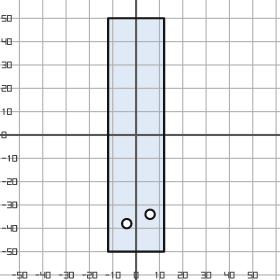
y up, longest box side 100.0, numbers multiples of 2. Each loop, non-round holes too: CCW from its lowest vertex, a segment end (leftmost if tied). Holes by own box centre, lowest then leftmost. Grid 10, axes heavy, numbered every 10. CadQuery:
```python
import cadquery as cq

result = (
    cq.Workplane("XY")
    .moveTo(-12.0, -50.0)
    .lineTo(12.0, -50.0)
    .lineTo(12.0, 50.0)
    .lineTo(-12.0, 50.0)
    .close()
    .moveTo(-4.0, -38.0)
    .circle(2.0)
    .moveTo(6.0, -34.0)
    .circle(2.0)
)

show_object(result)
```